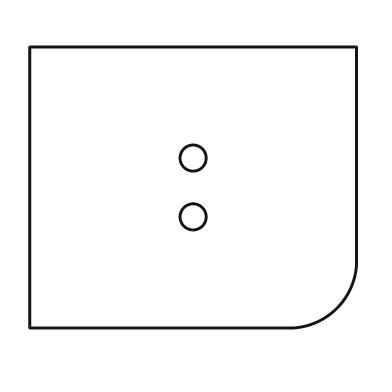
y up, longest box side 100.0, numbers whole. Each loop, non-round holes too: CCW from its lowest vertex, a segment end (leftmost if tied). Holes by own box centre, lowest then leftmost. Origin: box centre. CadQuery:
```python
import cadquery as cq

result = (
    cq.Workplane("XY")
    .moveTo(-50.0, -43.0)
    .lineTo(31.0, -43.0)
    .threePointArc((44.0, -37.0), (50.0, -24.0))
    .lineTo(50.0, 43.0)
    .lineTo(-50.0, 43.0)
    .close()
    .moveTo(0.0, -9.0)
    .circle(4.0)
    .moveTo(0.0, 9.0)
    .circle(4.0)
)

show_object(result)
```